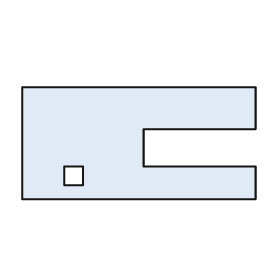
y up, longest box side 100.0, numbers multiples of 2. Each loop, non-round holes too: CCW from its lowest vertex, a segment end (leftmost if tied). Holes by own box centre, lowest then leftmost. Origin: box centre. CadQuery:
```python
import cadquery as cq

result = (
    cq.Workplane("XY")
    .moveTo(-50.0, -24.0)
    .lineTo(50.0, -24.0)
    .lineTo(50.0, -10.0)
    .lineTo(2.0, -10.0)
    .lineTo(2.0, 6.0)
    .lineTo(50.0, 6.0)
    .lineTo(50.0, 24.0)
    .lineTo(-50.0, 24.0)
    .close()
    .moveTo(-32.0, -18.0)
    .lineTo(-24.0, -18.0)
    .lineTo(-24.0, -10.0)
    .lineTo(-32.0, -10.0)
    .close()
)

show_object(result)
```